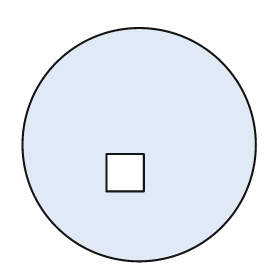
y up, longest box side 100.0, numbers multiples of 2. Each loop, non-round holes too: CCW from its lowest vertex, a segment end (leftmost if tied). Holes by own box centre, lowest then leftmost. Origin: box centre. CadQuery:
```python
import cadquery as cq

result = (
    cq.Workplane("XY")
    .moveTo(0.0, 0.0)
    .circle(50.0)
    .moveTo(-14.0, -20.0)
    .lineTo(2.0, -20.0)
    .lineTo(2.0, -4.0)
    .lineTo(-14.0, -4.0)
    .close()
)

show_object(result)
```